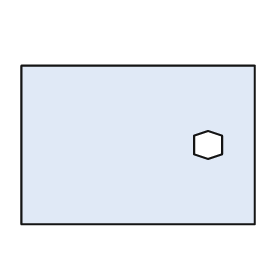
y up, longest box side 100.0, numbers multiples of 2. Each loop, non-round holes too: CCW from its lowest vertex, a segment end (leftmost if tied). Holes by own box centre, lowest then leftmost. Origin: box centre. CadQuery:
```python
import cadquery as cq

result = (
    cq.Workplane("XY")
    .moveTo(-50.0, -34.0)
    .lineTo(50.0, -34.0)
    .lineTo(50.0, 34.0)
    .lineTo(-50.0, 34.0)
    .close()
    .moveTo(30.0, -6.0)
    .lineTo(36.0, -4.0)
    .lineTo(36.0, 4.0)
    .lineTo(30.0, 6.0)
    .lineTo(24.0, 4.0)
    .lineTo(24.0, -4.0)
    .close()
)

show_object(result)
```